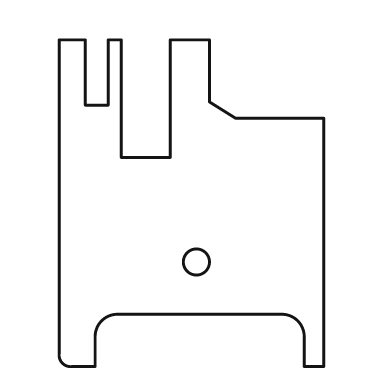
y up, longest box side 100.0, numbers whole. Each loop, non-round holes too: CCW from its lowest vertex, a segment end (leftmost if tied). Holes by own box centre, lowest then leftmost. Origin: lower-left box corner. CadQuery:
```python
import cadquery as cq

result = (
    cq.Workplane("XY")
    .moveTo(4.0, 0.0)
    .lineTo(11.0, 0.0)
    .lineTo(11.0, 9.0)
    .threePointArc((13.0, 14.0), (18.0, 16.0))
    .lineTo(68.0, 16.0)
    .threePointArc((73.0, 14.0), (75.0, 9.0))
    .lineTo(75.0, 0.0)
    .lineTo(81.0, 0.0)
    .lineTo(81.0, 76.0)
    .lineTo(54.0, 76.0)
    .lineTo(46.0, 81.0)
    .lineTo(46.0, 100.0)
    .lineTo(34.0, 100.0)
    .lineTo(34.0, 64.0)
    .lineTo(19.0, 64.0)
    .lineTo(19.0, 100.0)
    .lineTo(15.0, 100.0)
    .lineTo(15.0, 80.0)
    .lineTo(8.0, 80.0)
    .lineTo(8.0, 100.0)
    .lineTo(0.0, 100.0)
    .lineTo(0.0, 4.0)
    .threePointArc((1.0, 1.0), (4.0, 0.0))
    .close()
    .moveTo(42.0, 32.0)
    .circle(4.0)
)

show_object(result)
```